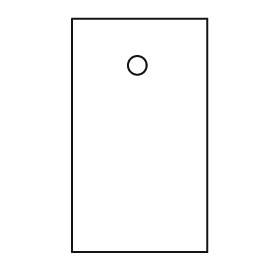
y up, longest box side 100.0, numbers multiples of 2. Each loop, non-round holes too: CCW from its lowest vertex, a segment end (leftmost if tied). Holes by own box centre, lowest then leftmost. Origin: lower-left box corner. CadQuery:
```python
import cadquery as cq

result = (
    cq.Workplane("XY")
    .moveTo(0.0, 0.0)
    .lineTo(58.0, 0.0)
    .lineTo(58.0, 100.0)
    .lineTo(0.0, 100.0)
    .close()
    .moveTo(28.0, 80.0)
    .circle(4.0)
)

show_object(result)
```